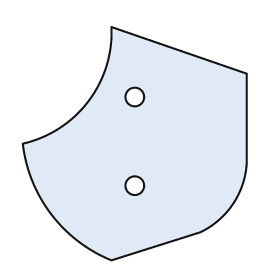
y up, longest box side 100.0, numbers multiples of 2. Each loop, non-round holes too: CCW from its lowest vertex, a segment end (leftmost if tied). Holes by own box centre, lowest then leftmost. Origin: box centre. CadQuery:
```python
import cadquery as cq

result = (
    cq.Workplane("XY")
    .moveTo(-10.0, -50.0)
    .lineTo(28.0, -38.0)
    .threePointArc((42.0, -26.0), (48.0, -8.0))
    .lineTo(48.0, 30.0)
    .lineTo(-10.0, 50.0)
    .threePointArc((-20.0, 18.0), (-48.0, 0.0))
    .threePointArc((-36.0, -30.0), (-10.0, -50.0))
    .close()
    .moveTo(0.0, -18.0)
    .circle(4.0)
    .moveTo(0.0, 20.0)
    .circle(4.0)
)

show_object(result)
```